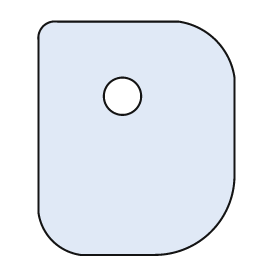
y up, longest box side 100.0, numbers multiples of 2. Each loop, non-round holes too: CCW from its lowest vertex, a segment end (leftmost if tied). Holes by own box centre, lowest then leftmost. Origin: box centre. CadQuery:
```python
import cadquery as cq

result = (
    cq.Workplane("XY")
    .moveTo(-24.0, -50.0)
    .lineTo(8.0, -50.0)
    .threePointArc((32.0, -40.0), (42.0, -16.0))
    .lineTo(42.0, 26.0)
    .threePointArc((34.0, 42.0), (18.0, 50.0))
    .lineTo(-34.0, 50.0)
    .threePointArc((-40.0, 48.0), (-42.0, 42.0))
    .lineTo(-42.0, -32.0)
    .threePointArc((-36.0, -44.0), (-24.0, -50.0))
    .close()
    .moveTo(-6.0, 18.0)
    .circle(8.0)
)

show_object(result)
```